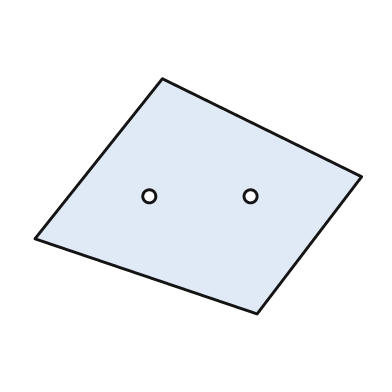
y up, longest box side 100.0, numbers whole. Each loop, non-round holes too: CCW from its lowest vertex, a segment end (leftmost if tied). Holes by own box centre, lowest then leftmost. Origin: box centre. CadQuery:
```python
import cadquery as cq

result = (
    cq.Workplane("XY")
    .moveTo(18.0, -36.0)
    .lineTo(50.0, 6.0)
    .lineTo(-11.0, 36.0)
    .lineTo(-50.0, -13.0)
    .close()
    .moveTo(-15.0, 0.0)
    .circle(2.0)
    .moveTo(16.0, 0.0)
    .circle(2.0)
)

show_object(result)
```